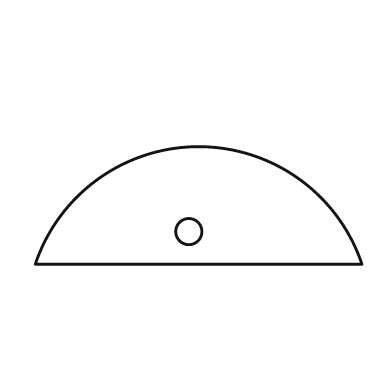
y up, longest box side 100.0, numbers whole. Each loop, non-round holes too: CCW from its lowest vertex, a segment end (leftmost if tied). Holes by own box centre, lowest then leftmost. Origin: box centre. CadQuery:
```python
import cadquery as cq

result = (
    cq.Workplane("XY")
    .moveTo(-50.0, -18.0)
    .lineTo(50.0, -18.0)
    .threePointArc((0.0, 18.0), (-50.0, -18.0))
    .close()
    .moveTo(-3.0, -8.0)
    .circle(4.0)
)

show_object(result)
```